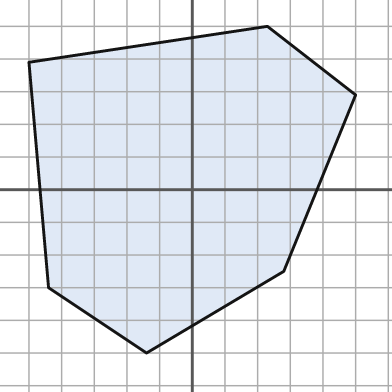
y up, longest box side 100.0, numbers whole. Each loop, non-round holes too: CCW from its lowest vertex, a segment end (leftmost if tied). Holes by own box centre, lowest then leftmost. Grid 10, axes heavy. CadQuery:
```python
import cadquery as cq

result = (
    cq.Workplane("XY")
    .moveTo(-14.0, -50.0)
    .lineTo(28.0, -25.0)
    .lineTo(50.0, 29.0)
    .lineTo(23.0, 50.0)
    .lineTo(-50.0, 39.0)
    .lineTo(-44.0, -30.0)
    .close()
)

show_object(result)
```